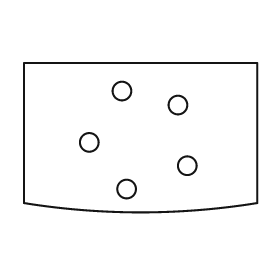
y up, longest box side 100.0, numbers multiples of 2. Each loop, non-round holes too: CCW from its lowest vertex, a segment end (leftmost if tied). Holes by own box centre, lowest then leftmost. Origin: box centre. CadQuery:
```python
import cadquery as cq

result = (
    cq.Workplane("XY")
    .moveTo(-50.0, -28.0)
    .threePointArc((0.0, -32.0), (50.0, -28.0))
    .lineTo(50.0, 32.0)
    .lineTo(-50.0, 32.0)
    .close()
    .moveTo(-6.0, -22.0)
    .circle(4.0)
    .moveTo(20.0, -12.0)
    .circle(4.0)
    .moveTo(-22.0, -2.0)
    .circle(4.0)
    .moveTo(16.0, 14.0)
    .circle(4.0)
    .moveTo(-8.0, 20.0)
    .circle(4.0)
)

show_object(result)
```